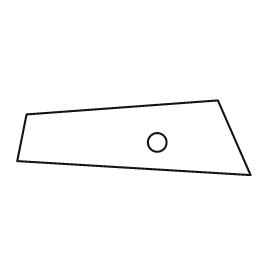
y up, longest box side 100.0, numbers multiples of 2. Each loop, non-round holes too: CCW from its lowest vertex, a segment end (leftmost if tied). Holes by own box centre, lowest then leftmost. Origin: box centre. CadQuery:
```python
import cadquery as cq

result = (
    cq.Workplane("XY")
    .moveTo(50.0, -16.0)
    .lineTo(36.0, 16.0)
    .lineTo(-46.0, 10.0)
    .lineTo(-50.0, -10.0)
    .close()
    .moveTo(10.0, -2.0)
    .circle(4.0)
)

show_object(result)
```